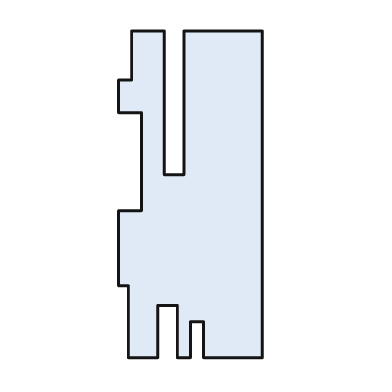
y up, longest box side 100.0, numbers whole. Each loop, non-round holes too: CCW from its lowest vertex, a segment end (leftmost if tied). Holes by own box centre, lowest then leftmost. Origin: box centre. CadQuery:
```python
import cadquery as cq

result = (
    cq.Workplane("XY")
    .moveTo(-19.0, -50.0)
    .lineTo(-10.0, -50.0)
    .lineTo(-10.0, -34.0)
    .lineTo(-4.0, -34.0)
    .lineTo(-4.0, -50.0)
    .lineTo(0.0, -50.0)
    .lineTo(0.0, -39.0)
    .lineTo(4.0, -39.0)
    .lineTo(4.0, -50.0)
    .lineTo(22.0, -50.0)
    .lineTo(22.0, 50.0)
    .lineTo(-2.0, 50.0)
    .lineTo(-2.0, 6.0)
    .lineTo(-8.0, 6.0)
    .lineTo(-8.0, 50.0)
    .lineTo(-18.0, 50.0)
    .lineTo(-18.0, 35.0)
    .lineTo(-22.0, 35.0)
    .lineTo(-22.0, 25.0)
    .lineTo(-15.0, 25.0)
    .lineTo(-15.0, -5.0)
    .lineTo(-22.0, -5.0)
    .lineTo(-22.0, -28.0)
    .lineTo(-19.0, -28.0)
    .close()
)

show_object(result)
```